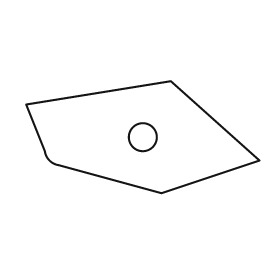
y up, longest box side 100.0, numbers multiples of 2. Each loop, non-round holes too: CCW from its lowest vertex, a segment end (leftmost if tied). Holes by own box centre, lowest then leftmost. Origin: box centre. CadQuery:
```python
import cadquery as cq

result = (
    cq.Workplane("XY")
    .moveTo(8.0, -24.0)
    .lineTo(50.0, -10.0)
    .lineTo(12.0, 24.0)
    .lineTo(-50.0, 14.0)
    .lineTo(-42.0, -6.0)
    .threePointArc((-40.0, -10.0), (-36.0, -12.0))
    .close()
    .moveTo(0.0, 0.0)
    .circle(6.0)
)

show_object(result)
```